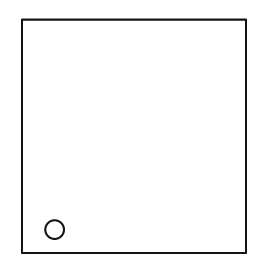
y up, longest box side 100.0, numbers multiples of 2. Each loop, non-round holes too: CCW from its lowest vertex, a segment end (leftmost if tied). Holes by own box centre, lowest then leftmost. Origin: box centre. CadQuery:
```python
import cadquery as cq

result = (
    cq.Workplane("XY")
    .moveTo(-48.0, -50.0)
    .lineTo(48.0, -50.0)
    .lineTo(48.0, 50.0)
    .lineTo(-48.0, 50.0)
    .close()
    .moveTo(-34.0, -40.0)
    .circle(4.0)
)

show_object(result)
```